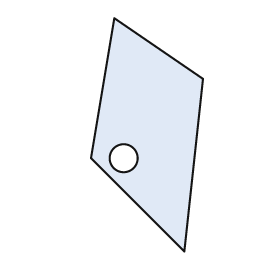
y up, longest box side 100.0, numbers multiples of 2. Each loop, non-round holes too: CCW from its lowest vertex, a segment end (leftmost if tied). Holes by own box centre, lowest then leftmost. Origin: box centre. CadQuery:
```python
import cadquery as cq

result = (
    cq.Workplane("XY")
    .moveTo(16.0, -50.0)
    .lineTo(24.0, 24.0)
    .lineTo(-14.0, 50.0)
    .lineTo(-24.0, -10.0)
    .close()
    .moveTo(-10.0, -10.0)
    .circle(6.0)
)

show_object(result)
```